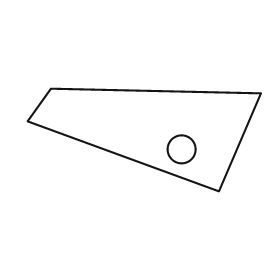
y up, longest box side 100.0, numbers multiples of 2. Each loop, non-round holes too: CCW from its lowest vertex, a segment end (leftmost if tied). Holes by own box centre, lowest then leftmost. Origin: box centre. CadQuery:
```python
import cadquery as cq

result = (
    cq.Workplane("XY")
    .moveTo(32.0, -22.0)
    .lineTo(50.0, 20.0)
    .lineTo(-40.0, 22.0)
    .lineTo(-50.0, 8.0)
    .close()
    .moveTo(16.0, -4.0)
    .circle(6.0)
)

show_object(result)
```